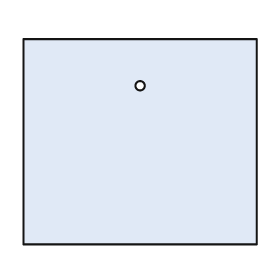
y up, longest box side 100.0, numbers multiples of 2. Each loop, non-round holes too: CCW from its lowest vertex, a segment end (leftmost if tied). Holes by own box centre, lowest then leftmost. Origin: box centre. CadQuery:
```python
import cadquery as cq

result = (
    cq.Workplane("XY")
    .moveTo(-50.0, -44.0)
    .lineTo(50.0, -44.0)
    .lineTo(50.0, 44.0)
    .lineTo(-50.0, 44.0)
    .close()
    .moveTo(0.0, 24.0)
    .circle(2.0)
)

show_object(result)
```